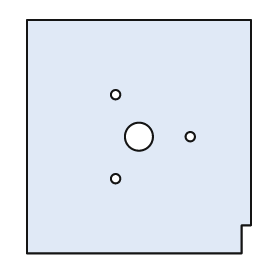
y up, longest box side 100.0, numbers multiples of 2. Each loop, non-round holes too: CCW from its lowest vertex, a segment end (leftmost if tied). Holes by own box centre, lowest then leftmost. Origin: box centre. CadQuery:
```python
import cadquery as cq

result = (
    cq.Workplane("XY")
    .moveTo(-48.0, -50.0)
    .lineTo(44.0, -50.0)
    .lineTo(44.0, -38.0)
    .lineTo(48.0, -38.0)
    .lineTo(48.0, 50.0)
    .lineTo(-48.0, 50.0)
    .close()
    .moveTo(-10.0, -18.0)
    .circle(2.0)
    .moveTo(0.0, 0.0)
    .circle(6.0)
    .moveTo(22.0, 0.0)
    .circle(2.0)
    .moveTo(-10.0, 18.0)
    .circle(2.0)
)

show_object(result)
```